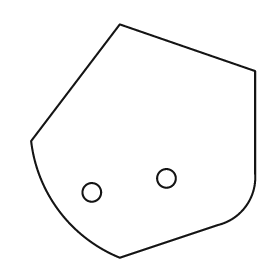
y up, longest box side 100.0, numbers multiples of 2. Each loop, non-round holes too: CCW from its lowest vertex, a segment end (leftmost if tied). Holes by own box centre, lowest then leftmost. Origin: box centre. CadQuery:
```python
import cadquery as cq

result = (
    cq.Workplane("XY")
    .moveTo(-10.0, -50.0)
    .lineTo(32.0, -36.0)
    .threePointArc((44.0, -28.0), (48.0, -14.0))
    .lineTo(48.0, 30.0)
    .lineTo(-10.0, 50.0)
    .lineTo(-48.0, 0.0)
    .threePointArc((-36.0, -30.0), (-10.0, -50.0))
    .close()
    .moveTo(-22.0, -22.0)
    .circle(4.0)
    .moveTo(10.0, -16.0)
    .circle(4.0)
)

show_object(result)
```